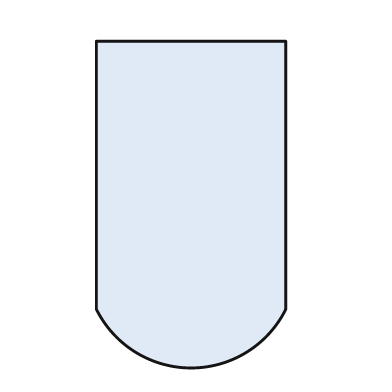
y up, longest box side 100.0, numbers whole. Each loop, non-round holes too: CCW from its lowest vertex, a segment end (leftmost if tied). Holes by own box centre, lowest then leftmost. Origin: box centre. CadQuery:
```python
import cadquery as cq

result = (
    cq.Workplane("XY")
    .moveTo(-29.0, -32.0)
    .threePointArc((0.0, -50.0), (29.0, -32.0))
    .lineTo(29.0, 50.0)
    .lineTo(-29.0, 50.0)
    .close()
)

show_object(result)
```